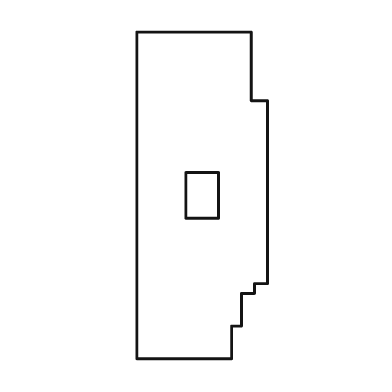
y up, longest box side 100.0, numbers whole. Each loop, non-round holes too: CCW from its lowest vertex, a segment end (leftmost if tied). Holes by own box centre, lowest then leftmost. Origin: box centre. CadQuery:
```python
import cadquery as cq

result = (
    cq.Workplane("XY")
    .moveTo(-20.0, -50.0)
    .lineTo(9.0, -50.0)
    .lineTo(9.0, -40.0)
    .lineTo(12.0, -40.0)
    .lineTo(12.0, -30.0)
    .lineTo(16.0, -30.0)
    .lineTo(16.0, -27.0)
    .lineTo(20.0, -27.0)
    .lineTo(20.0, 29.0)
    .lineTo(15.0, 29.0)
    .lineTo(15.0, 50.0)
    .lineTo(-20.0, 50.0)
    .close()
    .moveTo(-5.0, -7.0)
    .lineTo(5.0, -7.0)
    .lineTo(5.0, 7.0)
    .lineTo(-5.0, 7.0)
    .close()
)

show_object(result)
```